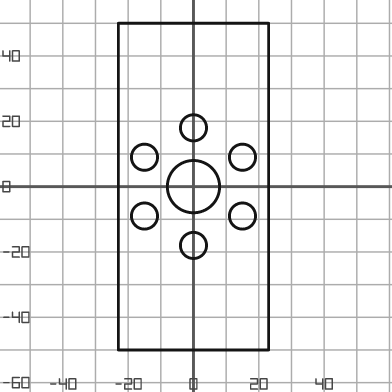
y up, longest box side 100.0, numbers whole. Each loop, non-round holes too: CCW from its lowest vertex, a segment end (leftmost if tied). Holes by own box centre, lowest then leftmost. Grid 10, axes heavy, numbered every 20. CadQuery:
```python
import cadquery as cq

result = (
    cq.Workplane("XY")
    .moveTo(-23.0, -50.0)
    .lineTo(23.0, -50.0)
    .lineTo(23.0, 50.0)
    .lineTo(-23.0, 50.0)
    .close()
    .moveTo(0.0, -18.0)
    .circle(4.0)
    .moveTo(-15.0, -9.0)
    .circle(4.0)
    .moveTo(15.0, -9.0)
    .circle(4.0)
    .moveTo(0.0, 0.0)
    .circle(8.0)
    .moveTo(-15.0, 9.0)
    .circle(4.0)
    .moveTo(15.0, 9.0)
    .circle(4.0)
    .moveTo(0.0, 18.0)
    .circle(4.0)
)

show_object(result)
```